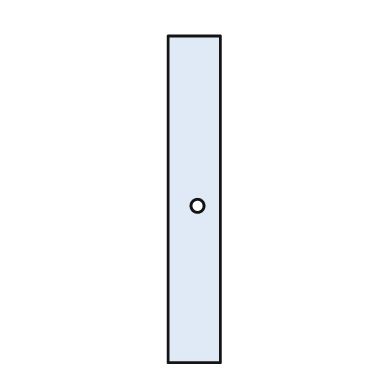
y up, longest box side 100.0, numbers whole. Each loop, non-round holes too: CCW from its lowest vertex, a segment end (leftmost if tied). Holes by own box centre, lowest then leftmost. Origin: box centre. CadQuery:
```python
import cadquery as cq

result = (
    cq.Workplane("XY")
    .moveTo(-8.0, -50.0)
    .lineTo(8.0, -50.0)
    .lineTo(8.0, 50.0)
    .lineTo(-8.0, 50.0)
    .close()
    .moveTo(1.0, -2.0)
    .circle(2.0)
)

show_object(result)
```